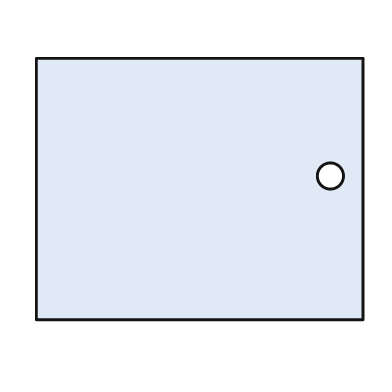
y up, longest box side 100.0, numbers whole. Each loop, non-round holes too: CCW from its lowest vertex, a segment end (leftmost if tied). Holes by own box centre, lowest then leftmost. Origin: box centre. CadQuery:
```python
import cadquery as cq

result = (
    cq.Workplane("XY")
    .moveTo(-50.0, -40.0)
    .lineTo(50.0, -40.0)
    .lineTo(50.0, 40.0)
    .lineTo(-50.0, 40.0)
    .close()
    .moveTo(40.0, 4.0)
    .circle(4.0)
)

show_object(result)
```